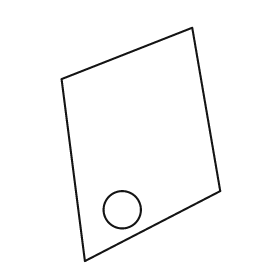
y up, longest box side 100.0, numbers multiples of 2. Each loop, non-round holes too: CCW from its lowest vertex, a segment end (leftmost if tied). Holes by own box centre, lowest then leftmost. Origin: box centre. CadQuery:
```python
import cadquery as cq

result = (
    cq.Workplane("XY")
    .moveTo(-24.0, -50.0)
    .lineTo(34.0, -20.0)
    .lineTo(22.0, 50.0)
    .lineTo(-34.0, 28.0)
    .close()
    .moveTo(-8.0, -28.0)
    .circle(8.0)
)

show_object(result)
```